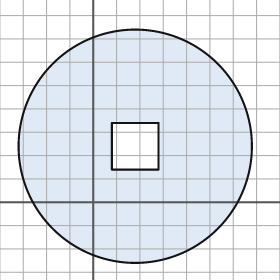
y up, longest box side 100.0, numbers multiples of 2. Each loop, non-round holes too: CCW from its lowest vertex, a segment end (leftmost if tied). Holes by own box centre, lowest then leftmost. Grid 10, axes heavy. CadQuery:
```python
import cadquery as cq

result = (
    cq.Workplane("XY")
    .moveTo(18.0, 24.0)
    .circle(50.0)
    .moveTo(8.0, 14.0)
    .lineTo(28.0, 14.0)
    .lineTo(28.0, 34.0)
    .lineTo(8.0, 34.0)
    .close()
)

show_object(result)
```